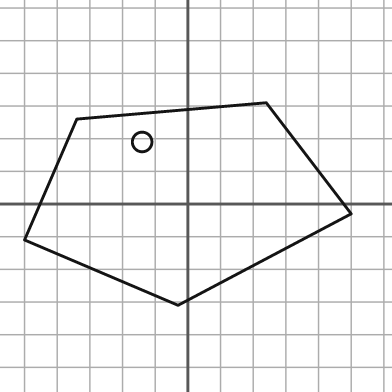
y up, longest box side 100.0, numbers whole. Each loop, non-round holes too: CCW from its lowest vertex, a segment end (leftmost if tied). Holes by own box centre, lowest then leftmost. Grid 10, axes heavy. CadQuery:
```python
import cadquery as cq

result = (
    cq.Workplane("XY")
    .moveTo(-3.0, -31.0)
    .lineTo(50.0, -3.0)
    .lineTo(24.0, 31.0)
    .lineTo(-34.0, 26.0)
    .lineTo(-50.0, -11.0)
    .close()
    .moveTo(-14.0, 19.0)
    .circle(3.0)
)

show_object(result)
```